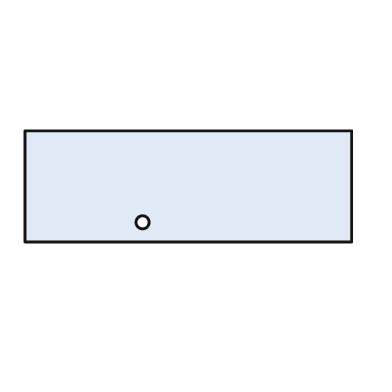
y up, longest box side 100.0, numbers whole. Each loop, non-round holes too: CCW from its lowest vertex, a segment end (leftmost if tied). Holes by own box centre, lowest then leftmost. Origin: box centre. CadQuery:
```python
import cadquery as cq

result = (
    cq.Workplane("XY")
    .moveTo(-50.0, -17.0)
    .lineTo(50.0, -17.0)
    .lineTo(50.0, 17.0)
    .lineTo(-50.0, 17.0)
    .close()
    .moveTo(-14.0, -11.0)
    .circle(2.0)
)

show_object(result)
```